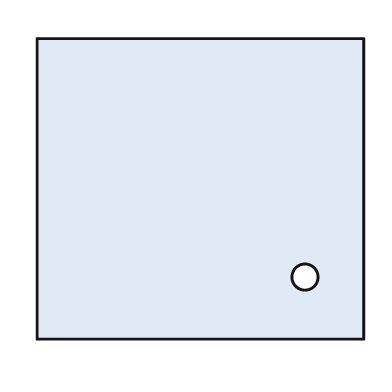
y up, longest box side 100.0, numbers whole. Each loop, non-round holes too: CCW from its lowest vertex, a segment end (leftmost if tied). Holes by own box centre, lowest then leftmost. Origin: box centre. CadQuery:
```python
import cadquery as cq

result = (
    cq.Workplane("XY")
    .moveTo(-50.0, -46.0)
    .lineTo(50.0, -46.0)
    .lineTo(50.0, 46.0)
    .lineTo(-50.0, 46.0)
    .close()
    .moveTo(32.0, -27.0)
    .circle(4.0)
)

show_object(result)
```